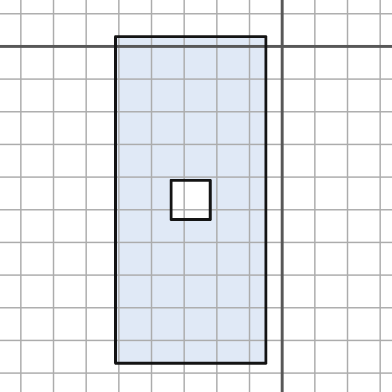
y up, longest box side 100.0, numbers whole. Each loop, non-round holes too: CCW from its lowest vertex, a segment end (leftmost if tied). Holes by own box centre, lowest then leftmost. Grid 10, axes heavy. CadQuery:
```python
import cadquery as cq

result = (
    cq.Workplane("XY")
    .moveTo(-51.0, -97.0)
    .lineTo(-5.0, -97.0)
    .lineTo(-5.0, 3.0)
    .lineTo(-51.0, 3.0)
    .close()
    .moveTo(-34.0, -53.0)
    .lineTo(-22.0, -53.0)
    .lineTo(-22.0, -41.0)
    .lineTo(-34.0, -41.0)
    .close()
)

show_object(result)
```